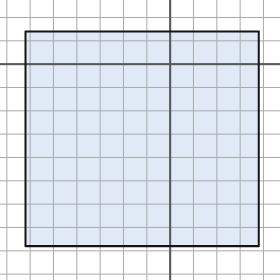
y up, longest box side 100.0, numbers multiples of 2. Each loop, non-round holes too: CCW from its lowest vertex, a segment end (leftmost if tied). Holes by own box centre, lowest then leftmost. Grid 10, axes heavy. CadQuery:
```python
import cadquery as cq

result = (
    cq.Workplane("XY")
    .moveTo(-62.0, -78.0)
    .lineTo(38.0, -78.0)
    .lineTo(38.0, 14.0)
    .lineTo(-62.0, 14.0)
    .close()
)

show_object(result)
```